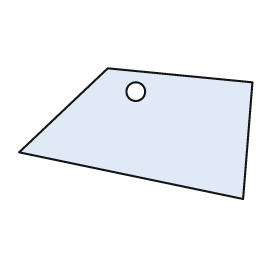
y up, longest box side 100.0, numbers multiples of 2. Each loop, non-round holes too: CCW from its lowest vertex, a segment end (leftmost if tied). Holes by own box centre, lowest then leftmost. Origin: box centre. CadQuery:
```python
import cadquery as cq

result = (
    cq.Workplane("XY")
    .moveTo(46.0, -28.0)
    .lineTo(50.0, 22.0)
    .lineTo(-12.0, 28.0)
    .lineTo(-50.0, -8.0)
    .close()
    .moveTo(0.0, 18.0)
    .circle(4.0)
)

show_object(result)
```